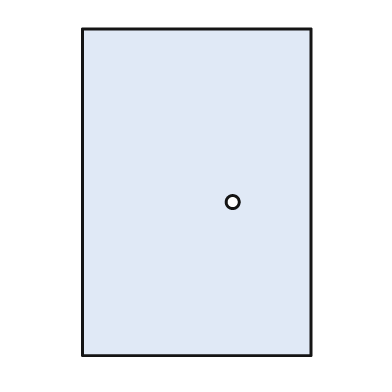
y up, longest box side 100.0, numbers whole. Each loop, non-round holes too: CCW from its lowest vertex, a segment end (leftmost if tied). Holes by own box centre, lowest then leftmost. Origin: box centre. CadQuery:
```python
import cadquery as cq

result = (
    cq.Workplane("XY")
    .moveTo(-35.0, -50.0)
    .lineTo(35.0, -50.0)
    .lineTo(35.0, 50.0)
    .lineTo(-35.0, 50.0)
    .close()
    .moveTo(11.0, -3.0)
    .circle(2.0)
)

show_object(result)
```